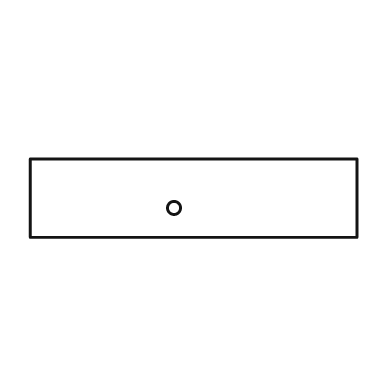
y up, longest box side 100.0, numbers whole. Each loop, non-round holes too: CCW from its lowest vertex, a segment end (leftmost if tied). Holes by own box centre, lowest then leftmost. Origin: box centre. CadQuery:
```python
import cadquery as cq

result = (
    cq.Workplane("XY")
    .moveTo(-50.0, -12.0)
    .lineTo(50.0, -12.0)
    .lineTo(50.0, 12.0)
    .lineTo(-50.0, 12.0)
    .close()
    .moveTo(-6.0, -3.0)
    .circle(2.0)
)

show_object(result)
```